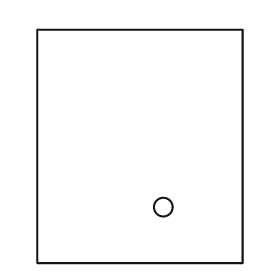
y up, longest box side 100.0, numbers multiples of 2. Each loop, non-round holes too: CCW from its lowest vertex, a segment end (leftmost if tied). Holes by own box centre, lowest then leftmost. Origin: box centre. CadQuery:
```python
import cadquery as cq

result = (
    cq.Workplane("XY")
    .moveTo(-44.0, -50.0)
    .lineTo(44.0, -50.0)
    .lineTo(44.0, 50.0)
    .lineTo(-44.0, 50.0)
    .close()
    .moveTo(10.0, -26.0)
    .circle(4.0)
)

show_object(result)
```